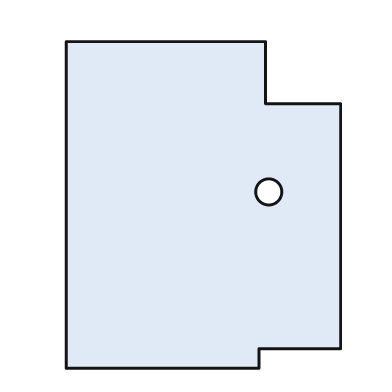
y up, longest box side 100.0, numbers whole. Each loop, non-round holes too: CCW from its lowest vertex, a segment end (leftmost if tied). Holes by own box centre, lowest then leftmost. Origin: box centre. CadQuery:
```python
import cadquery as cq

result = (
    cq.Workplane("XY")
    .moveTo(-42.0, -50.0)
    .lineTo(17.0, -50.0)
    .lineTo(17.0, -44.0)
    .lineTo(42.0, -44.0)
    .lineTo(42.0, 31.0)
    .lineTo(19.0, 31.0)
    .lineTo(19.0, 50.0)
    .lineTo(-42.0, 50.0)
    .close()
    .moveTo(20.0, 4.0)
    .circle(4.0)
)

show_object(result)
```